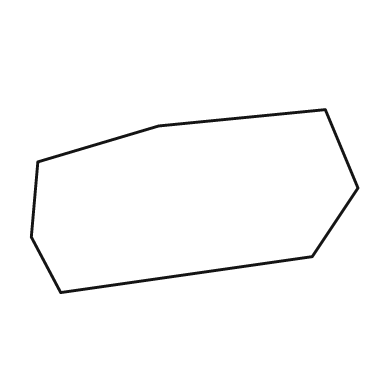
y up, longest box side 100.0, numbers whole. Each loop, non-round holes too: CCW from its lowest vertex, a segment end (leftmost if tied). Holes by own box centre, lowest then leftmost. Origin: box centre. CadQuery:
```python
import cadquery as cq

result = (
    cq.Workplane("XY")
    .moveTo(-41.0, -28.0)
    .lineTo(36.0, -17.0)
    .lineTo(50.0, 4.0)
    .lineTo(40.0, 28.0)
    .lineTo(-11.0, 23.0)
    .lineTo(-48.0, 12.0)
    .lineTo(-50.0, -11.0)
    .close()
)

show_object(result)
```